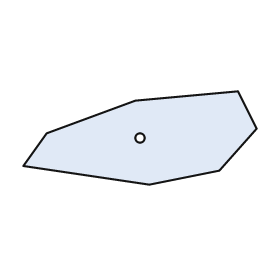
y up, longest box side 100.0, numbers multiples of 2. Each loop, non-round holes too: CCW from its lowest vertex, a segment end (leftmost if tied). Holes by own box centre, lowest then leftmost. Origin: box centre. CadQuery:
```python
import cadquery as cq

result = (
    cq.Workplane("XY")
    .moveTo(4.0, -20.0)
    .lineTo(34.0, -14.0)
    .lineTo(50.0, 4.0)
    .lineTo(42.0, 20.0)
    .lineTo(-2.0, 16.0)
    .lineTo(-40.0, 2.0)
    .lineTo(-50.0, -12.0)
    .close()
    .moveTo(0.0, 0.0)
    .circle(2.0)
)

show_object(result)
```